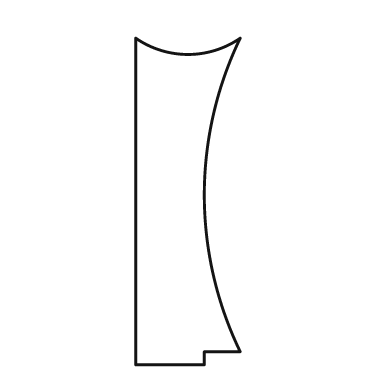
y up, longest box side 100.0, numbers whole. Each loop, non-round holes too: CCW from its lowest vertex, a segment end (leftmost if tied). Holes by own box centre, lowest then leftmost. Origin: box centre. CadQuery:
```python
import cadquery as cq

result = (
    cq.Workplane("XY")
    .moveTo(-16.0, -50.0)
    .lineTo(5.0, -50.0)
    .lineTo(5.0, -46.0)
    .lineTo(16.0, -46.0)
    .threePointArc((5.0, 2.0), (16.0, 50.0))
    .threePointArc((0.0, 45.0), (-16.0, 50.0))
    .close()
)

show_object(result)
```